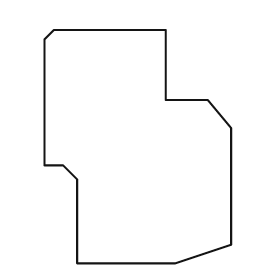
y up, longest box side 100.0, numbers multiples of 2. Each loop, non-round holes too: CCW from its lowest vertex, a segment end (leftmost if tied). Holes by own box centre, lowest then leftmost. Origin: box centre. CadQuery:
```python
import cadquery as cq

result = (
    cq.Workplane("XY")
    .moveTo(-26.0, -50.0)
    .lineTo(16.0, -50.0)
    .lineTo(40.0, -42.0)
    .lineTo(40.0, 8.0)
    .lineTo(30.0, 20.0)
    .lineTo(12.0, 20.0)
    .lineTo(12.0, 50.0)
    .lineTo(-36.0, 50.0)
    .lineTo(-40.0, 46.0)
    .lineTo(-40.0, -8.0)
    .lineTo(-32.0, -8.0)
    .lineTo(-26.0, -14.0)
    .close()
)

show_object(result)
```